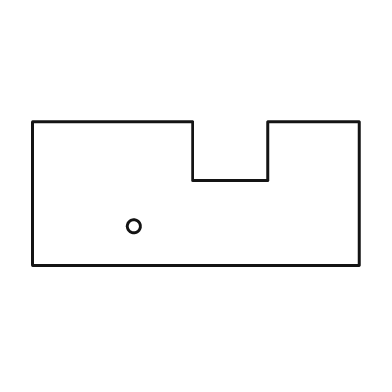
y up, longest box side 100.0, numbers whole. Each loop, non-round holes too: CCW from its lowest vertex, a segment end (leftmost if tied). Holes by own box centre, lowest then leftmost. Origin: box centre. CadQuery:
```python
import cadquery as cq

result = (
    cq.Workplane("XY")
    .moveTo(-50.0, -22.0)
    .lineTo(50.0, -22.0)
    .lineTo(50.0, 22.0)
    .lineTo(22.0, 22.0)
    .lineTo(22.0, 4.0)
    .lineTo(-1.0, 4.0)
    .lineTo(-1.0, 22.0)
    .lineTo(-50.0, 22.0)
    .close()
    .moveTo(-19.0, -10.0)
    .circle(2.0)
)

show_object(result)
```